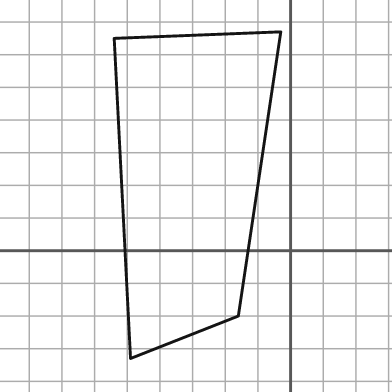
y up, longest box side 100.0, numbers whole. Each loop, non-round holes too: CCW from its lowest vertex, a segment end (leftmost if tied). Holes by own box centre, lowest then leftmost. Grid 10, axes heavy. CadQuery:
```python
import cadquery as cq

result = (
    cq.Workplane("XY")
    .moveTo(-49.0, -33.0)
    .lineTo(-16.0, -20.0)
    .lineTo(-3.0, 67.0)
    .lineTo(-54.0, 65.0)
    .close()
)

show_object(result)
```